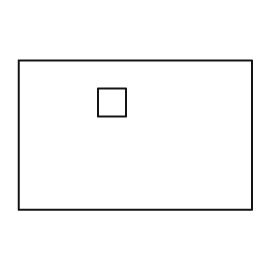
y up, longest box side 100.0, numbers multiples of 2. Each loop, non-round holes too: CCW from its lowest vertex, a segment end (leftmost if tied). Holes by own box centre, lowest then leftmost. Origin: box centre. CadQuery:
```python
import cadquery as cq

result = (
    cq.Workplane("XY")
    .moveTo(-50.0, -32.0)
    .lineTo(50.0, -32.0)
    .lineTo(50.0, 32.0)
    .lineTo(-50.0, 32.0)
    .close()
    .moveTo(-16.0, 8.0)
    .lineTo(-4.0, 8.0)
    .lineTo(-4.0, 20.0)
    .lineTo(-16.0, 20.0)
    .close()
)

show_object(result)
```